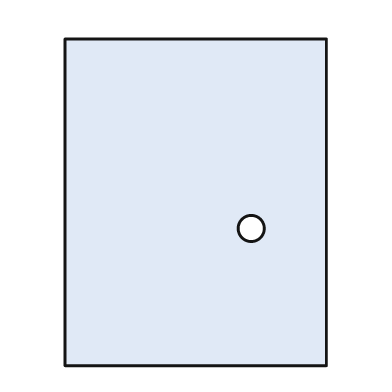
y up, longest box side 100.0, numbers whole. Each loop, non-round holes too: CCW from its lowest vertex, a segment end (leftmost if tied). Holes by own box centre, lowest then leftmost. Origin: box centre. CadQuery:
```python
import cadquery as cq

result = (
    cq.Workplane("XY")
    .moveTo(-40.0, -50.0)
    .lineTo(40.0, -50.0)
    .lineTo(40.0, 50.0)
    .lineTo(-40.0, 50.0)
    .close()
    .moveTo(17.0, -8.0)
    .circle(4.0)
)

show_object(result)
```